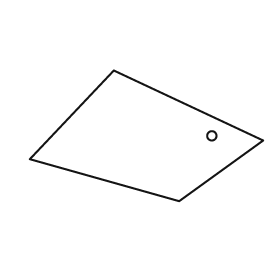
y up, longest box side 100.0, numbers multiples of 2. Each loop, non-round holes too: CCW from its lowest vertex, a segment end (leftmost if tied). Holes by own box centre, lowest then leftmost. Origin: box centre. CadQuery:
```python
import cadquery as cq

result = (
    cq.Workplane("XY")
    .moveTo(14.0, -28.0)
    .lineTo(50.0, -2.0)
    .lineTo(-14.0, 28.0)
    .lineTo(-50.0, -10.0)
    .close()
    .moveTo(28.0, 0.0)
    .circle(2.0)
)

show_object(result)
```